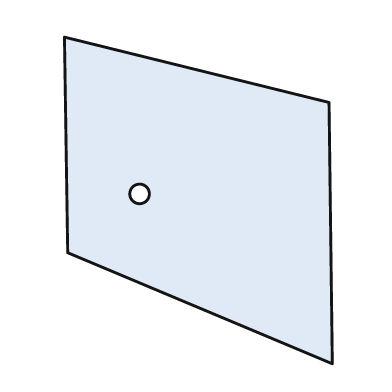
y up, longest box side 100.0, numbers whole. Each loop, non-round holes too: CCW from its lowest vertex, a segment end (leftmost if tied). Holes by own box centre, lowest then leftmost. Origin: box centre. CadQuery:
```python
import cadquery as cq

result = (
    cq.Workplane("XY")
    .moveTo(41.0, -50.0)
    .lineTo(40.0, 30.0)
    .lineTo(-41.0, 50.0)
    .lineTo(-40.0, -16.0)
    .close()
    .moveTo(-18.0, 2.0)
    .circle(3.0)
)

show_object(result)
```